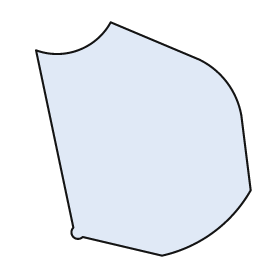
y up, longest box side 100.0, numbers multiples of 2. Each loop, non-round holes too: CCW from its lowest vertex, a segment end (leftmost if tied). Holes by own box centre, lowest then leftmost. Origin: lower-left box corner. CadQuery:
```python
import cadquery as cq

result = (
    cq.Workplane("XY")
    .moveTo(54.0, 0.0)
    .threePointArc((76.0, 10.0), (92.0, 28.0))
    .lineTo(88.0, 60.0)
    .threePointArc((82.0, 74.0), (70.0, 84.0))
    .lineTo(32.0, 100.0)
    .threePointArc((18.0, 88.0), (0.0, 88.0))
    .lineTo(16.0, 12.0)
    .threePointArc((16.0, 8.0), (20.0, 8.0))
    .close()
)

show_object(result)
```